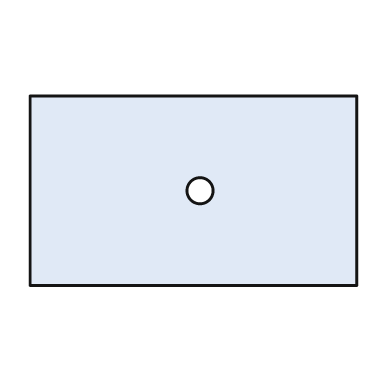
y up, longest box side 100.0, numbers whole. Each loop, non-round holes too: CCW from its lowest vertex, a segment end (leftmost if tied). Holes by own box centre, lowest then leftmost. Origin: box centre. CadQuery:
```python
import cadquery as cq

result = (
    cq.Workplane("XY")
    .moveTo(-50.0, -29.0)
    .lineTo(50.0, -29.0)
    .lineTo(50.0, 29.0)
    .lineTo(-50.0, 29.0)
    .close()
    .moveTo(2.0, 0.0)
    .circle(4.0)
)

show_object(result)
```